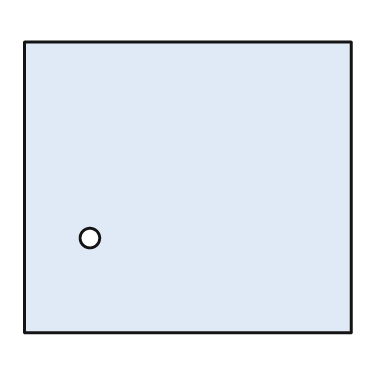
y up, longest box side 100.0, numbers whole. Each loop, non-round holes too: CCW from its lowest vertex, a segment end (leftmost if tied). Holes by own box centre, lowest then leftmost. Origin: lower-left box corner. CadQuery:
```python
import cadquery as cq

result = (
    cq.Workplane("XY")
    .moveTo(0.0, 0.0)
    .lineTo(100.0, 0.0)
    .lineTo(100.0, 89.0)
    .lineTo(0.0, 89.0)
    .close()
    .moveTo(20.0, 29.0)
    .circle(3.0)
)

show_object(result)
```